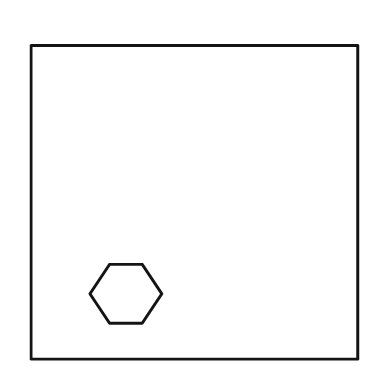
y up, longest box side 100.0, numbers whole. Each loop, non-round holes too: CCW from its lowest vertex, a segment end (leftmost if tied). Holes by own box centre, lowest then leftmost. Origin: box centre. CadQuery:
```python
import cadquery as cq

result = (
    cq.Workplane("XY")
    .moveTo(-50.0, -48.0)
    .lineTo(50.0, -48.0)
    .lineTo(50.0, 48.0)
    .lineTo(-50.0, 48.0)
    .close()
    .moveTo(-26.0, -37.0)
    .lineTo(-16.0, -37.0)
    .lineTo(-10.0, -28.0)
    .lineTo(-16.0, -19.0)
    .lineTo(-26.0, -19.0)
    .lineTo(-32.0, -28.0)
    .close()
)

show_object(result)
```